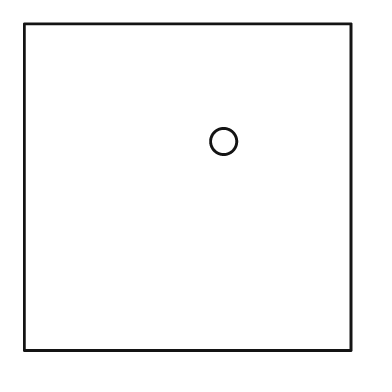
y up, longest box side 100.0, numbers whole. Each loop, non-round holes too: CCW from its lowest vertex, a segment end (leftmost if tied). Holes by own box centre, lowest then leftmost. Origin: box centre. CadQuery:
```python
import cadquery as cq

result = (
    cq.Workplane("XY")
    .moveTo(-50.0, -50.0)
    .lineTo(50.0, -50.0)
    .lineTo(50.0, 50.0)
    .lineTo(-50.0, 50.0)
    .close()
    .moveTo(11.0, 14.0)
    .circle(4.0)
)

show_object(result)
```